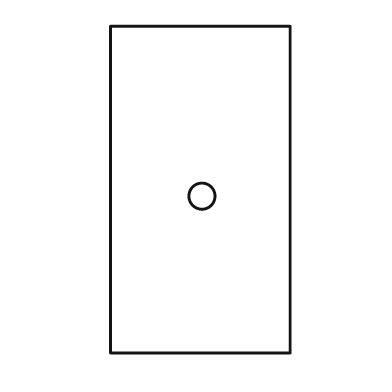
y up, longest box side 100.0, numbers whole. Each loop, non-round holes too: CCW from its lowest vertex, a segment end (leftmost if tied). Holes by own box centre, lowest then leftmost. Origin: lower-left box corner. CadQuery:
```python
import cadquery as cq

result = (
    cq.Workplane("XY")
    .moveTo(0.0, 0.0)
    .lineTo(55.0, 0.0)
    .lineTo(55.0, 100.0)
    .lineTo(0.0, 100.0)
    .close()
    .moveTo(28.0, 48.0)
    .circle(4.0)
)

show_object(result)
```